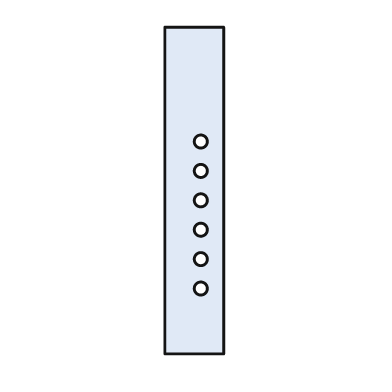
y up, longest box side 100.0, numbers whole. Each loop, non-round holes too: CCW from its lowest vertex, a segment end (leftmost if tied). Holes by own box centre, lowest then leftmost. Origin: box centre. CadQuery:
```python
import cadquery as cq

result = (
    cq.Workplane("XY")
    .moveTo(-9.0, -50.0)
    .lineTo(9.0, -50.0)
    .lineTo(9.0, 50.0)
    .lineTo(-9.0, 50.0)
    .close()
    .moveTo(2.0, -30.0)
    .circle(2.0)
    .moveTo(2.0, -21.0)
    .circle(2.0)
    .moveTo(2.0, -12.0)
    .circle(2.0)
    .moveTo(2.0, -3.0)
    .circle(2.0)
    .moveTo(2.0, 6.0)
    .circle(2.0)
    .moveTo(2.0, 15.0)
    .circle(2.0)
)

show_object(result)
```